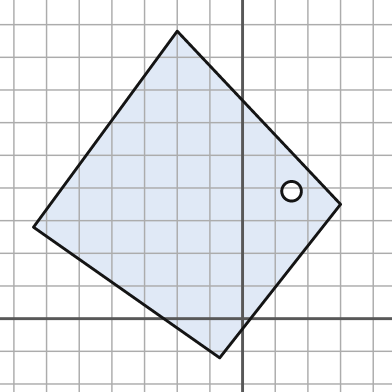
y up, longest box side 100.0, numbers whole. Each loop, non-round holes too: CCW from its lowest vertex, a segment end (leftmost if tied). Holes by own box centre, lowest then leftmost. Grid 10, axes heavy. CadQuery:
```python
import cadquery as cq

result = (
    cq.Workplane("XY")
    .moveTo(-7.0, -12.0)
    .lineTo(30.0, 35.0)
    .lineTo(-20.0, 88.0)
    .lineTo(-64.0, 28.0)
    .close()
    .moveTo(15.0, 39.0)
    .circle(3.0)
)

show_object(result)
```